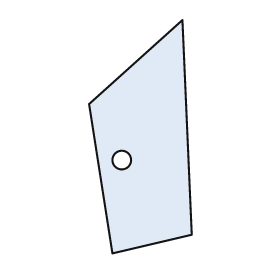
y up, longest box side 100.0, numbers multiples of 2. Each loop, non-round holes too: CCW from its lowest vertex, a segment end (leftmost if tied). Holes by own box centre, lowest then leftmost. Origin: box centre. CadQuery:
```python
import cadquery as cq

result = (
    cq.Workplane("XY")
    .moveTo(-12.0, -50.0)
    .lineTo(22.0, -42.0)
    .lineTo(18.0, 50.0)
    .lineTo(-22.0, 14.0)
    .close()
    .moveTo(-8.0, -10.0)
    .circle(4.0)
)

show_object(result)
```